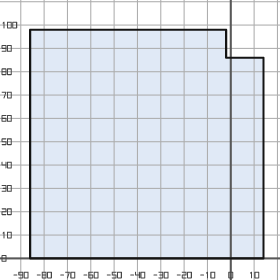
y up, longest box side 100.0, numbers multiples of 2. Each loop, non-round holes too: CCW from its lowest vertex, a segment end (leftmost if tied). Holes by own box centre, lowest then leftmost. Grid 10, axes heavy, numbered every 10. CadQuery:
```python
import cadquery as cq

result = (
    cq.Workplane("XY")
    .moveTo(-86.0, 0.0)
    .lineTo(14.0, 0.0)
    .lineTo(14.0, 86.0)
    .lineTo(-2.0, 86.0)
    .lineTo(-2.0, 98.0)
    .lineTo(-86.0, 98.0)
    .close()
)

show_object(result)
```